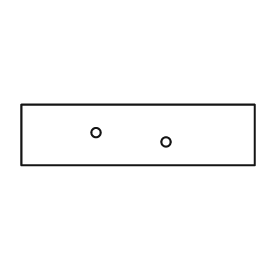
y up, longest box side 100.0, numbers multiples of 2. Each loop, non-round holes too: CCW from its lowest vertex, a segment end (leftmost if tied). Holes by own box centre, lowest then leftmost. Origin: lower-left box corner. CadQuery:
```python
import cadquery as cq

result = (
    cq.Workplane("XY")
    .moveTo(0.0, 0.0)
    .lineTo(100.0, 0.0)
    .lineTo(100.0, 26.0)
    .lineTo(0.0, 26.0)
    .close()
    .moveTo(62.0, 10.0)
    .circle(2.0)
    .moveTo(32.0, 14.0)
    .circle(2.0)
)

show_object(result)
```